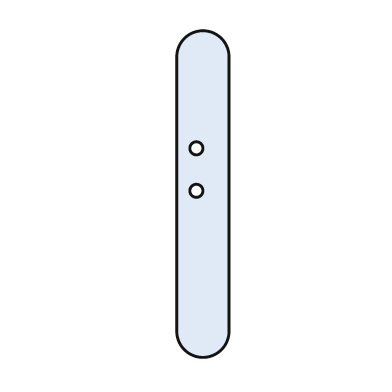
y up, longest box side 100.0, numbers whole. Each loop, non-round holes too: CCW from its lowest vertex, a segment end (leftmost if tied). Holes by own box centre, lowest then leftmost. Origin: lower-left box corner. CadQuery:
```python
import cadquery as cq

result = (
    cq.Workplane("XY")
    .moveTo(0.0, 8.0)
    .threePointArc((8.0, 0.0), (16.0, 8.0))
    .lineTo(16.0, 92.0)
    .threePointArc((8.0, 100.0), (0.0, 92.0))
    .close()
    .moveTo(6.0, 51.0)
    .circle(2.0)
    .moveTo(6.0, 64.0)
    .circle(2.0)
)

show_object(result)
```